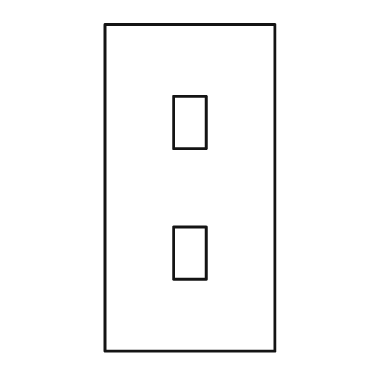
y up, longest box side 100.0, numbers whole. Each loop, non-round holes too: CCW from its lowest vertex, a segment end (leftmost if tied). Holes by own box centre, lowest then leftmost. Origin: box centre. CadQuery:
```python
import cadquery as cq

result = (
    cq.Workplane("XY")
    .moveTo(-26.0, -50.0)
    .lineTo(26.0, -50.0)
    .lineTo(26.0, 50.0)
    .lineTo(-26.0, 50.0)
    .close()
    .moveTo(-5.0, -28.0)
    .lineTo(5.0, -28.0)
    .lineTo(5.0, -12.0)
    .lineTo(-5.0, -12.0)
    .close()
    .moveTo(-5.0, 12.0)
    .lineTo(5.0, 12.0)
    .lineTo(5.0, 28.0)
    .lineTo(-5.0, 28.0)
    .close()
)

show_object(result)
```